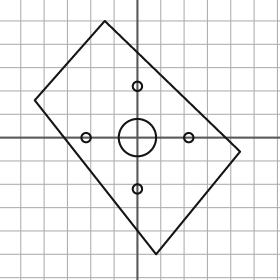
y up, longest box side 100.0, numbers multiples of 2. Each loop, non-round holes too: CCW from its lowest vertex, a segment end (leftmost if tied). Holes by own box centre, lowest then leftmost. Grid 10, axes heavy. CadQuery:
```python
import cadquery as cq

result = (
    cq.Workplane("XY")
    .moveTo(8.0, -50.0)
    .lineTo(44.0, -6.0)
    .lineTo(-14.0, 50.0)
    .lineTo(-44.0, 16.0)
    .close()
    .moveTo(0.0, -22.0)
    .circle(2.0)
    .moveTo(-22.0, 0.0)
    .circle(2.0)
    .moveTo(0.0, 0.0)
    .circle(8.0)
    .moveTo(22.0, 0.0)
    .circle(2.0)
    .moveTo(0.0, 22.0)
    .circle(2.0)
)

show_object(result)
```